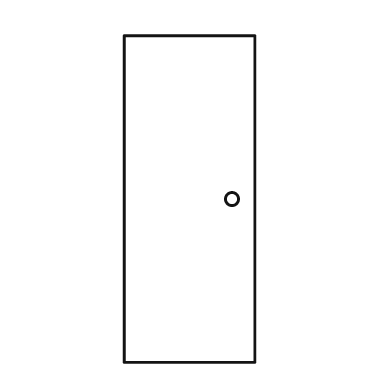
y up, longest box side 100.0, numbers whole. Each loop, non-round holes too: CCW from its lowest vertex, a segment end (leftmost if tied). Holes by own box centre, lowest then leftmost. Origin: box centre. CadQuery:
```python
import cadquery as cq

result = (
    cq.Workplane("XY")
    .moveTo(-20.0, -50.0)
    .lineTo(20.0, -50.0)
    .lineTo(20.0, 50.0)
    .lineTo(-20.0, 50.0)
    .close()
    .moveTo(13.0, 0.0)
    .circle(2.0)
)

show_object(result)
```